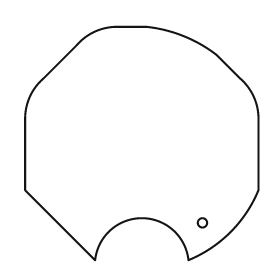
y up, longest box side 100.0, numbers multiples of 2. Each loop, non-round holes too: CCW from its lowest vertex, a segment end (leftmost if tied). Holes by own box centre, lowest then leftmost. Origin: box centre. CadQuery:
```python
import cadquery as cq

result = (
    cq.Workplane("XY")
    .moveTo(-20.0, -50.0)
    .threePointArc((0.0, -32.0), (20.0, -50.0))
    .threePointArc((38.0, -38.0), (50.0, -20.0))
    .lineTo(50.0, 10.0)
    .threePointArc((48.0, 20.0), (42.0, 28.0))
    .lineTo(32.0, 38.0)
    .threePointArc((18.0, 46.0), (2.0, 50.0))
    .lineTo(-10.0, 50.0)
    .threePointArc((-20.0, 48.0), (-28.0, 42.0))
    .lineTo(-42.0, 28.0)
    .threePointArc((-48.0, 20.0), (-50.0, 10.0))
    .lineTo(-50.0, -20.0)
    .close()
    .moveTo(26.0, -34.0)
    .circle(2.0)
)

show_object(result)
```